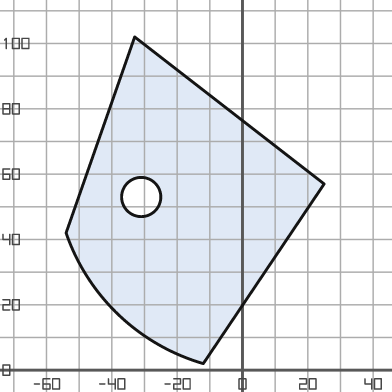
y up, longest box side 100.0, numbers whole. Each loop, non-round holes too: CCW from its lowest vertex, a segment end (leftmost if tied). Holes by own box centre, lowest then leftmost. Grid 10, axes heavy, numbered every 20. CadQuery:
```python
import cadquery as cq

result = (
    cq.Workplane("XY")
    .moveTo(-12.0, 2.0)
    .lineTo(25.0, 57.0)
    .lineTo(-33.0, 102.0)
    .lineTo(-54.0, 42.0)
    .threePointArc((-38.0, 17.0), (-12.0, 2.0))
    .close()
    .moveTo(-31.0, 53.0)
    .circle(6.0)
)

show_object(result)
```